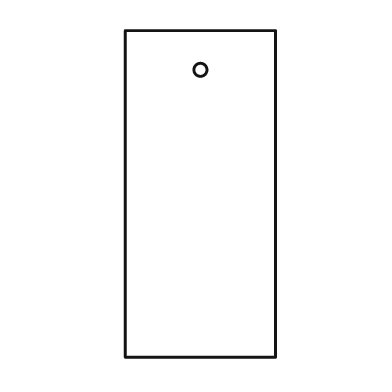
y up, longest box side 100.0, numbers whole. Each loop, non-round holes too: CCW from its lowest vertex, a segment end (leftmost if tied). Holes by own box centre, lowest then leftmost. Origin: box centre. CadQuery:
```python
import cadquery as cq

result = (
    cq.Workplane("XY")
    .moveTo(-23.0, -50.0)
    .lineTo(23.0, -50.0)
    .lineTo(23.0, 50.0)
    .lineTo(-23.0, 50.0)
    .close()
    .moveTo(0.0, 38.0)
    .circle(2.0)
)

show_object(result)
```